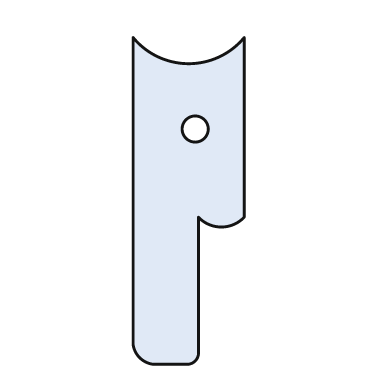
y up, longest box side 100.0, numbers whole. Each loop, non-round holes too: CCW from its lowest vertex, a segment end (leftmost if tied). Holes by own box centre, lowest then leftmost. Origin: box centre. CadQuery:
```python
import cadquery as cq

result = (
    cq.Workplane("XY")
    .moveTo(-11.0, -50.0)
    .lineTo(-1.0, -50.0)
    .threePointArc((2.0, -49.0), (3.0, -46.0))
    .lineTo(3.0, -5.0)
    .threePointArc((10.0, -8.0), (17.0, -5.0))
    .lineTo(17.0, 50.0)
    .threePointArc((0.0, 42.0), (-17.0, 50.0))
    .lineTo(-17.0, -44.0)
    .threePointArc((-15.0, -48.0), (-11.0, -50.0))
    .close()
    .moveTo(2.0, 22.0)
    .circle(4.0)
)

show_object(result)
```